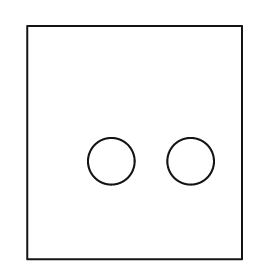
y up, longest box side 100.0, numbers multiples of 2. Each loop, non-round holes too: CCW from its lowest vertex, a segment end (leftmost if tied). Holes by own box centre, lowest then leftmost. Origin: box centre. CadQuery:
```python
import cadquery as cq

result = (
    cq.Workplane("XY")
    .moveTo(-46.0, -50.0)
    .lineTo(46.0, -50.0)
    .lineTo(46.0, 50.0)
    .lineTo(-46.0, 50.0)
    .close()
    .moveTo(-10.0, -8.0)
    .circle(10.0)
    .moveTo(24.0, -8.0)
    .circle(10.0)
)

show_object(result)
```